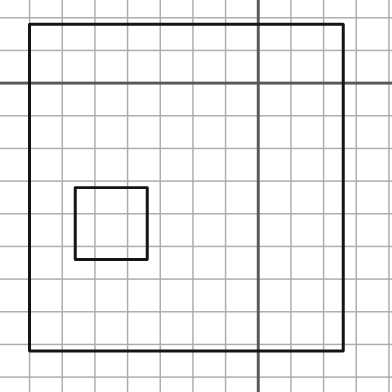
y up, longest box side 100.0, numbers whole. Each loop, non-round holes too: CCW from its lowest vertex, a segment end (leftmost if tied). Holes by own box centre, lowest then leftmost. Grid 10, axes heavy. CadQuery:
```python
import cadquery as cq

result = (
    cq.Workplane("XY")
    .moveTo(-70.0, -82.0)
    .lineTo(26.0, -82.0)
    .lineTo(26.0, 18.0)
    .lineTo(-70.0, 18.0)
    .close()
    .moveTo(-56.0, -54.0)
    .lineTo(-34.0, -54.0)
    .lineTo(-34.0, -32.0)
    .lineTo(-56.0, -32.0)
    .close()
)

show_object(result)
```